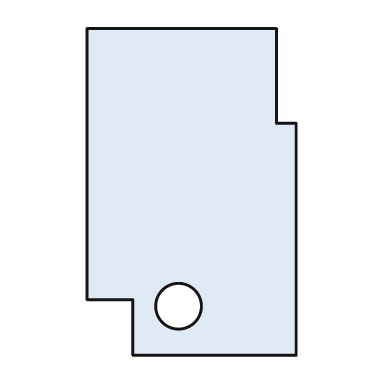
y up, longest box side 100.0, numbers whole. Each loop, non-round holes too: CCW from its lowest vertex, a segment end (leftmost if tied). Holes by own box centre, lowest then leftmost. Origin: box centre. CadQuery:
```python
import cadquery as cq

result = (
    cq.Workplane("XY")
    .moveTo(-18.0, -50.0)
    .lineTo(32.0, -50.0)
    .lineTo(32.0, 21.0)
    .lineTo(26.0, 21.0)
    .lineTo(26.0, 50.0)
    .lineTo(-32.0, 50.0)
    .lineTo(-32.0, -33.0)
    .lineTo(-18.0, -33.0)
    .close()
    .moveTo(-4.0, -35.0)
    .circle(7.0)
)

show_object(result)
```